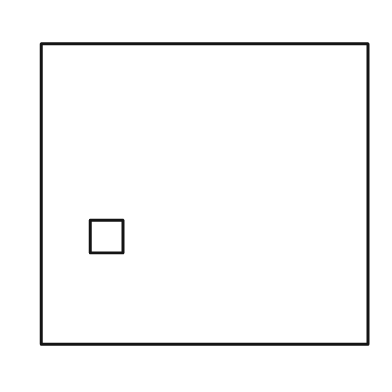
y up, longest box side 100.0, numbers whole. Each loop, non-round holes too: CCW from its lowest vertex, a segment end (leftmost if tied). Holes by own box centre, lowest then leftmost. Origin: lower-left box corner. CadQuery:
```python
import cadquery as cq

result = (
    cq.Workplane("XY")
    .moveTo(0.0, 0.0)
    .lineTo(100.0, 0.0)
    .lineTo(100.0, 92.0)
    .lineTo(0.0, 92.0)
    .close()
    .moveTo(15.0, 28.0)
    .lineTo(25.0, 28.0)
    .lineTo(25.0, 38.0)
    .lineTo(15.0, 38.0)
    .close()
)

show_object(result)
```